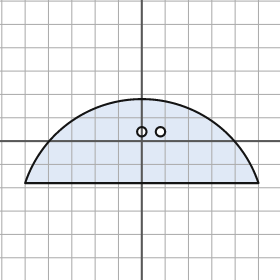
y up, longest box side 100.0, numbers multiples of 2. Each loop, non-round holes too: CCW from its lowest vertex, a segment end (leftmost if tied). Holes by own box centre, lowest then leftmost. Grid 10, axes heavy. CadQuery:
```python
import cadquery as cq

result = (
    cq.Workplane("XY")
    .moveTo(-50.0, -18.0)
    .lineTo(50.0, -18.0)
    .threePointArc((0.0, 18.0), (-50.0, -18.0))
    .close()
    .moveTo(0.0, 4.0)
    .circle(2.0)
    .moveTo(8.0, 4.0)
    .circle(2.0)
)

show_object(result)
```